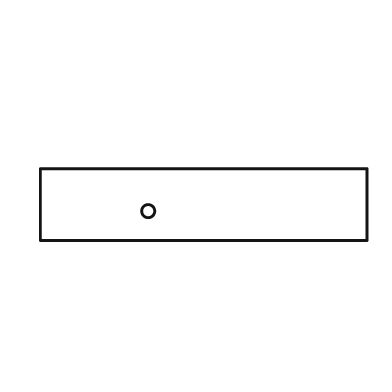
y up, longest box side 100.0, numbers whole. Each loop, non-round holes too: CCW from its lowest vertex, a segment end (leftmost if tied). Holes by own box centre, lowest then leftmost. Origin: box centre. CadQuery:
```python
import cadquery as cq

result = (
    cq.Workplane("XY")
    .moveTo(-50.0, -11.0)
    .lineTo(50.0, -11.0)
    .lineTo(50.0, 11.0)
    .lineTo(-50.0, 11.0)
    .close()
    .moveTo(-17.0, -2.0)
    .circle(2.0)
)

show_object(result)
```